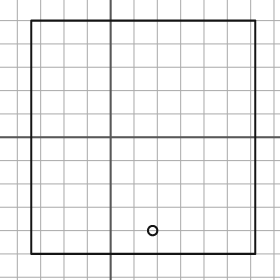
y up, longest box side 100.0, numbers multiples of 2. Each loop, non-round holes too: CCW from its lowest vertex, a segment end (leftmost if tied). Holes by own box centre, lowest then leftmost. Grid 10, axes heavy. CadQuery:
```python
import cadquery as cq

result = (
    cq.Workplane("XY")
    .moveTo(-34.0, -50.0)
    .lineTo(62.0, -50.0)
    .lineTo(62.0, 50.0)
    .lineTo(-34.0, 50.0)
    .close()
    .moveTo(18.0, -40.0)
    .circle(2.0)
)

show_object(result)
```